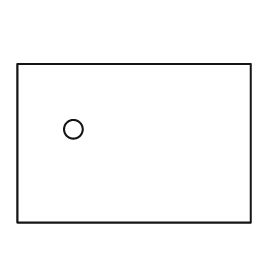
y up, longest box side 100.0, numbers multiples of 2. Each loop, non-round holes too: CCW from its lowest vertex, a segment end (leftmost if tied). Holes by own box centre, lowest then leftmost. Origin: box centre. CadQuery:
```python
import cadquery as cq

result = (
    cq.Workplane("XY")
    .moveTo(-50.0, -34.0)
    .lineTo(50.0, -34.0)
    .lineTo(50.0, 34.0)
    .lineTo(-50.0, 34.0)
    .close()
    .moveTo(-26.0, 6.0)
    .circle(4.0)
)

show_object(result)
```